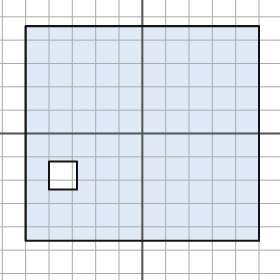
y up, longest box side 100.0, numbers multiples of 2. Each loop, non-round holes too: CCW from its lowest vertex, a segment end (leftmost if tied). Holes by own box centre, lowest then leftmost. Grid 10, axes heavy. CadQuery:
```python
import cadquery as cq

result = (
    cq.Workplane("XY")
    .moveTo(-50.0, -46.0)
    .lineTo(50.0, -46.0)
    .lineTo(50.0, 46.0)
    .lineTo(-50.0, 46.0)
    .close()
    .moveTo(-40.0, -24.0)
    .lineTo(-28.0, -24.0)
    .lineTo(-28.0, -12.0)
    .lineTo(-40.0, -12.0)
    .close()
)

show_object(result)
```